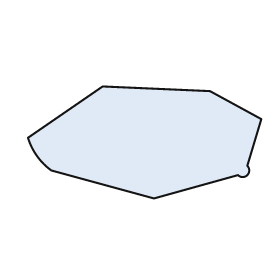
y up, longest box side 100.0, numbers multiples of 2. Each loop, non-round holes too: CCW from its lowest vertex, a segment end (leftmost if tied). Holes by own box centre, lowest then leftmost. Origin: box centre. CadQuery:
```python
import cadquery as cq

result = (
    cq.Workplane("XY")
    .moveTo(4.0, -24.0)
    .lineTo(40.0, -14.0)
    .threePointArc((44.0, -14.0), (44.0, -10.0))
    .lineTo(50.0, 10.0)
    .lineTo(28.0, 22.0)
    .lineTo(-18.0, 24.0)
    .lineTo(-50.0, 2.0)
    .threePointArc((-46.0, -6.0), (-40.0, -12.0))
    .close()
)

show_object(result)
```